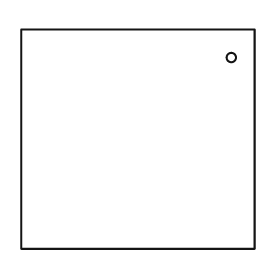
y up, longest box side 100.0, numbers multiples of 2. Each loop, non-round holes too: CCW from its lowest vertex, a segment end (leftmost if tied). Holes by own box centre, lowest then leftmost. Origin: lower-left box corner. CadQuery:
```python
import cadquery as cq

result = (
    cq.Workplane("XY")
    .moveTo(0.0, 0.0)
    .lineTo(100.0, 0.0)
    .lineTo(100.0, 94.0)
    .lineTo(0.0, 94.0)
    .close()
    .moveTo(90.0, 82.0)
    .circle(2.0)
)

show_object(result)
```